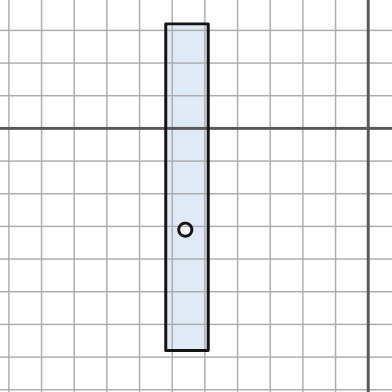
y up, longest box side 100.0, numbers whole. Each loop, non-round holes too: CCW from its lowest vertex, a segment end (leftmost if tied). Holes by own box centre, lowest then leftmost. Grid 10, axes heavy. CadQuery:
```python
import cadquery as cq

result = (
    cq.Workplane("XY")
    .moveTo(-62.0, -68.0)
    .lineTo(-49.0, -68.0)
    .lineTo(-49.0, 32.0)
    .lineTo(-62.0, 32.0)
    .close()
    .moveTo(-56.0, -31.0)
    .circle(2.0)
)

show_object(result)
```